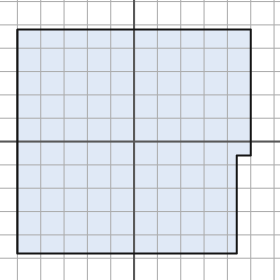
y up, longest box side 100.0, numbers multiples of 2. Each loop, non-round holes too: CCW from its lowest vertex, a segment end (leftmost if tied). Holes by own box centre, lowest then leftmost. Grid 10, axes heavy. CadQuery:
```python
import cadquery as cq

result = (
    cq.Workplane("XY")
    .moveTo(-50.0, -48.0)
    .lineTo(44.0, -48.0)
    .lineTo(44.0, -6.0)
    .lineTo(50.0, -6.0)
    .lineTo(50.0, 48.0)
    .lineTo(-50.0, 48.0)
    .close()
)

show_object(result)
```